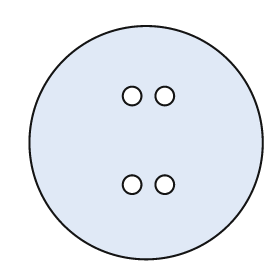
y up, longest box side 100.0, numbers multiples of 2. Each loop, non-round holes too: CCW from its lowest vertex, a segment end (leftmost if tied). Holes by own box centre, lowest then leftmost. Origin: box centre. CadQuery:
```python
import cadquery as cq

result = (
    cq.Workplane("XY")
    .moveTo(0.0, 0.0)
    .circle(50.0)
    .moveTo(-6.0, -18.0)
    .circle(4.0)
    .moveTo(8.0, -18.0)
    .circle(4.0)
    .moveTo(-6.0, 20.0)
    .circle(4.0)
    .moveTo(8.0, 20.0)
    .circle(4.0)
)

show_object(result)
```